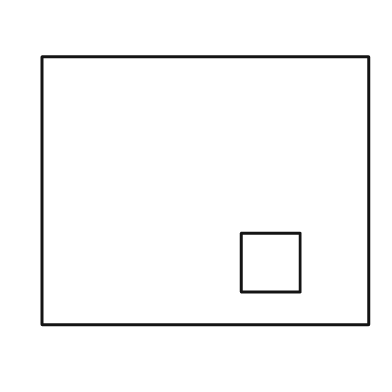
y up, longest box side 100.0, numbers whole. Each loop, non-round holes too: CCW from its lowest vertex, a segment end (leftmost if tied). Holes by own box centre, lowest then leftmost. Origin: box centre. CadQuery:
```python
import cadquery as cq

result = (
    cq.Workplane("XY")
    .moveTo(-50.0, -41.0)
    .lineTo(50.0, -41.0)
    .lineTo(50.0, 41.0)
    .lineTo(-50.0, 41.0)
    .close()
    .moveTo(11.0, -31.0)
    .lineTo(29.0, -31.0)
    .lineTo(29.0, -13.0)
    .lineTo(11.0, -13.0)
    .close()
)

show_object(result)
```